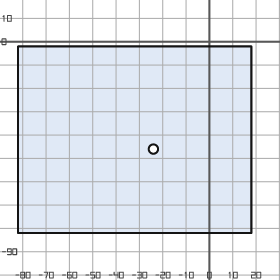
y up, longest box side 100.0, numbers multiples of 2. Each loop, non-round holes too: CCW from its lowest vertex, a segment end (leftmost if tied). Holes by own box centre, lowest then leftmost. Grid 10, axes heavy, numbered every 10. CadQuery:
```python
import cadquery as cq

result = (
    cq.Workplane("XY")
    .moveTo(-82.0, -82.0)
    .lineTo(18.0, -82.0)
    .lineTo(18.0, -2.0)
    .lineTo(-82.0, -2.0)
    .close()
    .moveTo(-24.0, -46.0)
    .circle(2.0)
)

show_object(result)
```